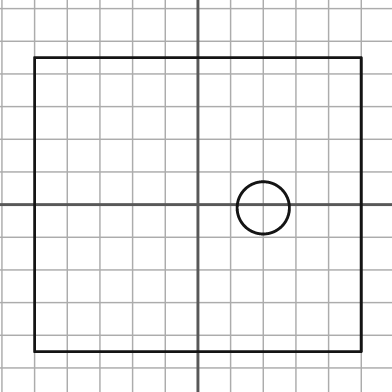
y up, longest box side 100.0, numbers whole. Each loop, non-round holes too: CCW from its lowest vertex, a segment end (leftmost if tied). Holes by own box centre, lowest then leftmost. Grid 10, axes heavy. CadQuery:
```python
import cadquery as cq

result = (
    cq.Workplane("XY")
    .moveTo(-50.0, -45.0)
    .lineTo(50.0, -45.0)
    .lineTo(50.0, 45.0)
    .lineTo(-50.0, 45.0)
    .close()
    .moveTo(20.0, -1.0)
    .circle(8.0)
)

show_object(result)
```